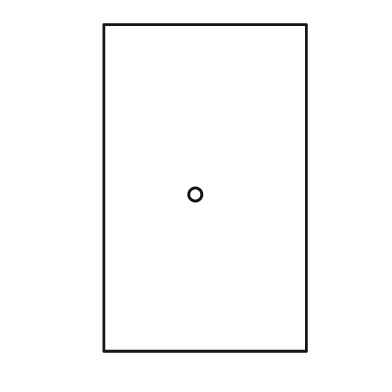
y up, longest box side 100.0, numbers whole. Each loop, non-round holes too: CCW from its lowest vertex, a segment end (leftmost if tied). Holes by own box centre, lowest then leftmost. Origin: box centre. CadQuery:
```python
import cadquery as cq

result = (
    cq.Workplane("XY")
    .moveTo(-31.0, -50.0)
    .lineTo(31.0, -50.0)
    .lineTo(31.0, 50.0)
    .lineTo(-31.0, 50.0)
    .close()
    .moveTo(-3.0, -2.0)
    .circle(2.0)
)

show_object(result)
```